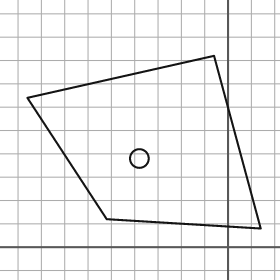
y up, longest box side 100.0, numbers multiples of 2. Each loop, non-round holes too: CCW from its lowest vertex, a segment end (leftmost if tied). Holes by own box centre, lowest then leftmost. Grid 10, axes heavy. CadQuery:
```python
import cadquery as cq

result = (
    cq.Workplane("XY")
    .moveTo(14.0, 8.0)
    .lineTo(-6.0, 82.0)
    .lineTo(-86.0, 64.0)
    .lineTo(-52.0, 12.0)
    .close()
    .moveTo(-38.0, 38.0)
    .circle(4.0)
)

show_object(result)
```